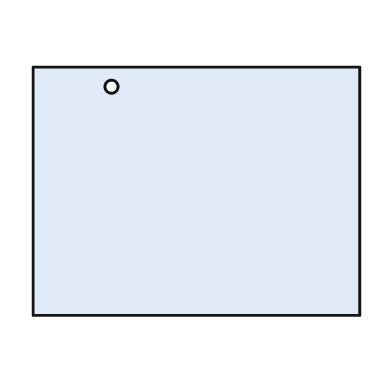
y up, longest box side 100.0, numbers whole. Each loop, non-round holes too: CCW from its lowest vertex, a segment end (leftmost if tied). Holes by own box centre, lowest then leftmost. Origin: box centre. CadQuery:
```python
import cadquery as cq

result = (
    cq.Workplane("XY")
    .moveTo(-50.0, -38.0)
    .lineTo(50.0, -38.0)
    .lineTo(50.0, 38.0)
    .lineTo(-50.0, 38.0)
    .close()
    .moveTo(-26.0, 32.0)
    .circle(2.0)
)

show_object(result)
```